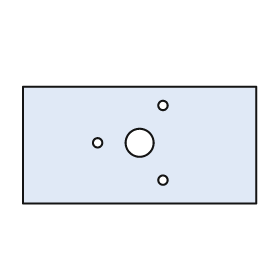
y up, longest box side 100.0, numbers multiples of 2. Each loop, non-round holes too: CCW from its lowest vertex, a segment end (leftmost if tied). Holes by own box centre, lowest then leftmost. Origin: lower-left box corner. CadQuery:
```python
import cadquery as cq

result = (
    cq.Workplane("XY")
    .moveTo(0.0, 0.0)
    .lineTo(100.0, 0.0)
    .lineTo(100.0, 50.0)
    .lineTo(0.0, 50.0)
    .close()
    .moveTo(60.0, 10.0)
    .circle(2.0)
    .moveTo(32.0, 26.0)
    .circle(2.0)
    .moveTo(50.0, 26.0)
    .circle(6.0)
    .moveTo(60.0, 42.0)
    .circle(2.0)
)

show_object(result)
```